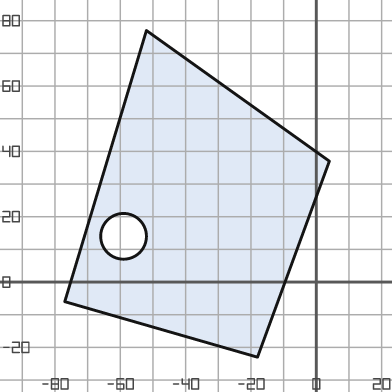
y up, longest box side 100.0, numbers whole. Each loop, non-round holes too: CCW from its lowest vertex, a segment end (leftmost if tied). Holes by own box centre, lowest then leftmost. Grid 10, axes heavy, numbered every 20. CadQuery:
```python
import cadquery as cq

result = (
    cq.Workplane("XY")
    .moveTo(-18.0, -23.0)
    .lineTo(4.0, 37.0)
    .lineTo(-52.0, 77.0)
    .lineTo(-77.0, -6.0)
    .close()
    .moveTo(-59.0, 14.0)
    .circle(7.0)
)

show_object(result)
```